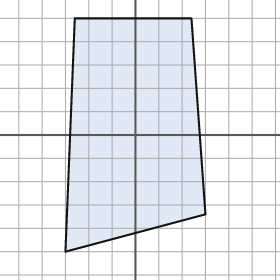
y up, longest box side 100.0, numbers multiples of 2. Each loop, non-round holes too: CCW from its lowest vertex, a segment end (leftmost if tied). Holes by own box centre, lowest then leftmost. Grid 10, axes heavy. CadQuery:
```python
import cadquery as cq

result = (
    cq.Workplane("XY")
    .moveTo(-30.0, -50.0)
    .lineTo(30.0, -34.0)
    .lineTo(24.0, 50.0)
    .lineTo(-26.0, 50.0)
    .close()
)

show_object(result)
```